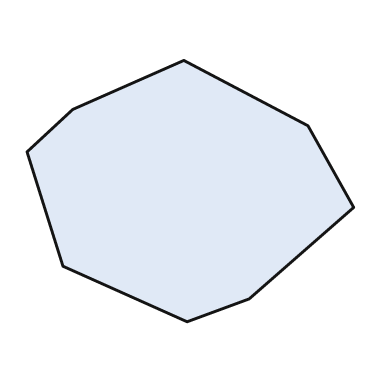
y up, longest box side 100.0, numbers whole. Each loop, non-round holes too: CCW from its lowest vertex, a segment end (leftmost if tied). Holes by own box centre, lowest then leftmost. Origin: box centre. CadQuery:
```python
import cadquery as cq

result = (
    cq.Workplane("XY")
    .moveTo(-1.0, -40.0)
    .lineTo(18.0, -33.0)
    .lineTo(50.0, -5.0)
    .lineTo(36.0, 20.0)
    .lineTo(-2.0, 40.0)
    .lineTo(-36.0, 25.0)
    .lineTo(-50.0, 12.0)
    .lineTo(-39.0, -23.0)
    .close()
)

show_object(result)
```